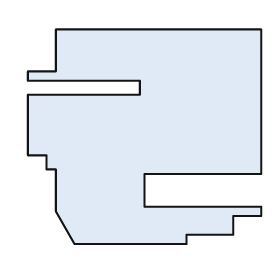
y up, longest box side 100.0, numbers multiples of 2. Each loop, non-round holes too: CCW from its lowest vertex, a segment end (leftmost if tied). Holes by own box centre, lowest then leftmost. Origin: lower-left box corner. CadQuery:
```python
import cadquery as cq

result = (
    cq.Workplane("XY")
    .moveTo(20.0, 0.0)
    .lineTo(68.0, 0.0)
    .lineTo(68.0, 4.0)
    .lineTo(88.0, 4.0)
    .lineTo(88.0, 12.0)
    .lineTo(100.0, 12.0)
    .lineTo(100.0, 16.0)
    .lineTo(50.0, 16.0)
    .lineTo(50.0, 30.0)
    .lineTo(100.0, 30.0)
    .lineTo(100.0, 92.0)
    .lineTo(12.0, 92.0)
    .lineTo(12.0, 74.0)
    .lineTo(0.0, 74.0)
    .lineTo(0.0, 70.0)
    .lineTo(48.0, 70.0)
    .lineTo(48.0, 64.0)
    .lineTo(0.0, 64.0)
    .lineTo(0.0, 38.0)
    .lineTo(8.0, 38.0)
    .lineTo(8.0, 32.0)
    .lineTo(12.0, 32.0)
    .lineTo(12.0, 14.0)
    .close()
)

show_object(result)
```